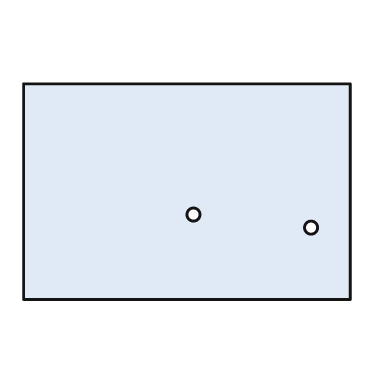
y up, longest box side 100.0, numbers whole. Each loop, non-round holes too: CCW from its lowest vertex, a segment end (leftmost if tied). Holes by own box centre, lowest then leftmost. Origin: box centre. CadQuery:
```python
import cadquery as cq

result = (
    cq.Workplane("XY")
    .moveTo(-50.0, -33.0)
    .lineTo(50.0, -33.0)
    .lineTo(50.0, 33.0)
    .lineTo(-50.0, 33.0)
    .close()
    .moveTo(38.0, -11.0)
    .circle(2.0)
    .moveTo(2.0, -7.0)
    .circle(2.0)
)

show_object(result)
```